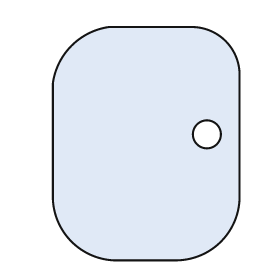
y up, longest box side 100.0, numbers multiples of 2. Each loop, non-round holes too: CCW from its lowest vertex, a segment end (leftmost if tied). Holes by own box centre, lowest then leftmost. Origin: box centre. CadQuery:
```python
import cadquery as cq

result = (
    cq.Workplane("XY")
    .moveTo(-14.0, -50.0)
    .lineTo(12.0, -50.0)
    .threePointArc((32.0, -42.0), (40.0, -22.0))
    .lineTo(40.0, 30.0)
    .threePointArc((34.0, 44.0), (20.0, 50.0))
    .lineTo(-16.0, 50.0)
    .threePointArc((-32.0, 42.0), (-40.0, 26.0))
    .lineTo(-40.0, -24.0)
    .threePointArc((-32.0, -42.0), (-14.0, -50.0))
    .close()
    .moveTo(26.0, 4.0)
    .circle(6.0)
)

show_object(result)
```